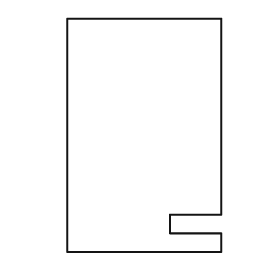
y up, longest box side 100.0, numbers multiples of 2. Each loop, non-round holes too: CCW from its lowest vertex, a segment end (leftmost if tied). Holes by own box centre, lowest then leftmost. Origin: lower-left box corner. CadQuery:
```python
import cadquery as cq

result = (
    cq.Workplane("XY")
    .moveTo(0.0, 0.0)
    .lineTo(66.0, 0.0)
    .lineTo(66.0, 8.0)
    .lineTo(44.0, 8.0)
    .lineTo(44.0, 16.0)
    .lineTo(66.0, 16.0)
    .lineTo(66.0, 100.0)
    .lineTo(0.0, 100.0)
    .close()
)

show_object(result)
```